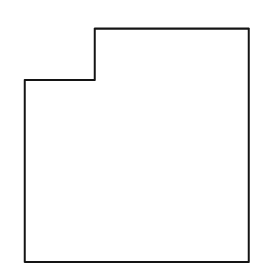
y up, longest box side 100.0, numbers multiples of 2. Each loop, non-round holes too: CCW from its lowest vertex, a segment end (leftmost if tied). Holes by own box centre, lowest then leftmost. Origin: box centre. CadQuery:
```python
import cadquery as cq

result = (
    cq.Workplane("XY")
    .moveTo(-48.0, -50.0)
    .lineTo(48.0, -50.0)
    .lineTo(48.0, 50.0)
    .lineTo(-18.0, 50.0)
    .lineTo(-18.0, 28.0)
    .lineTo(-48.0, 28.0)
    .close()
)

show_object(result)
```